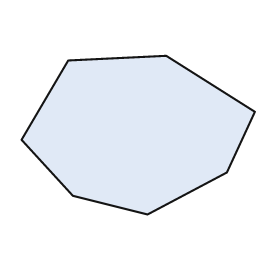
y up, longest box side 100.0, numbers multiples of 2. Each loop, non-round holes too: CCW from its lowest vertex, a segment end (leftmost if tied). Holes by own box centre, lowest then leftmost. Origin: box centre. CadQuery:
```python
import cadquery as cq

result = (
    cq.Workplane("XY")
    .moveTo(4.0, -34.0)
    .lineTo(38.0, -16.0)
    .lineTo(50.0, 10.0)
    .lineTo(12.0, 34.0)
    .lineTo(-30.0, 32.0)
    .lineTo(-50.0, -2.0)
    .lineTo(-28.0, -26.0)
    .close()
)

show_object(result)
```